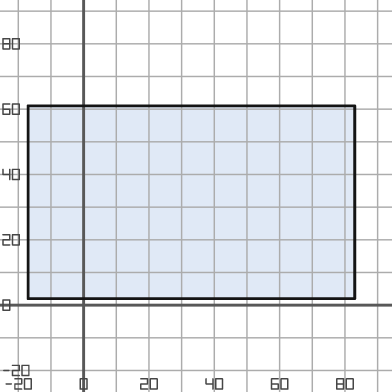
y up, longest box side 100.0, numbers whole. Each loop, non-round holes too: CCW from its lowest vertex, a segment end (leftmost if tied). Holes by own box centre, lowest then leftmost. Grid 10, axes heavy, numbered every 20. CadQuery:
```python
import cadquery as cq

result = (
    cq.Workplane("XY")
    .moveTo(-17.0, 2.0)
    .lineTo(83.0, 2.0)
    .lineTo(83.0, 61.0)
    .lineTo(-17.0, 61.0)
    .close()
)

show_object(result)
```